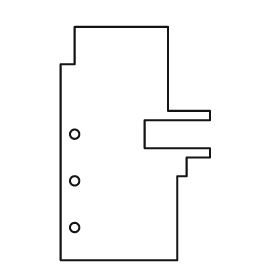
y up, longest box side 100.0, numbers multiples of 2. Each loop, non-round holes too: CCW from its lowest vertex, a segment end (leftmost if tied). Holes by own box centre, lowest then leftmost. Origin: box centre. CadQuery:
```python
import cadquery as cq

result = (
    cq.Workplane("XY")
    .moveTo(-32.0, -50.0)
    .lineTo(18.0, -50.0)
    .lineTo(18.0, -14.0)
    .lineTo(22.0, -14.0)
    .lineTo(22.0, -6.0)
    .lineTo(32.0, -6.0)
    .lineTo(32.0, -2.0)
    .lineTo(4.0, -2.0)
    .lineTo(4.0, 10.0)
    .lineTo(32.0, 10.0)
    .lineTo(32.0, 14.0)
    .lineTo(14.0, 14.0)
    .lineTo(14.0, 50.0)
    .lineTo(-26.0, 50.0)
    .lineTo(-26.0, 34.0)
    .lineTo(-32.0, 34.0)
    .close()
    .moveTo(-26.0, -36.0)
    .circle(2.0)
    .moveTo(-26.0, -16.0)
    .circle(2.0)
    .moveTo(-26.0, 4.0)
    .circle(2.0)
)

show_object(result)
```